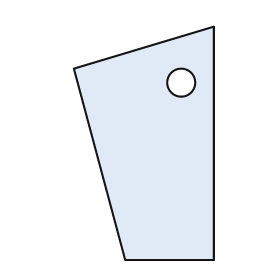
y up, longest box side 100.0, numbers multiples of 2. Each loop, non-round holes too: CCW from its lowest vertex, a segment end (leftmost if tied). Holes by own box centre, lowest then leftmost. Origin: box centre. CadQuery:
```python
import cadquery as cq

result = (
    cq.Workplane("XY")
    .moveTo(-8.0, -50.0)
    .lineTo(30.0, -50.0)
    .lineTo(30.0, 50.0)
    .lineTo(-30.0, 32.0)
    .close()
    .moveTo(16.0, 26.0)
    .circle(6.0)
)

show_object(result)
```